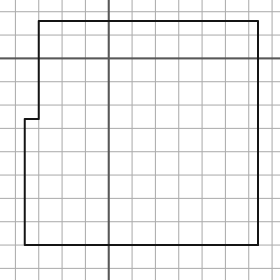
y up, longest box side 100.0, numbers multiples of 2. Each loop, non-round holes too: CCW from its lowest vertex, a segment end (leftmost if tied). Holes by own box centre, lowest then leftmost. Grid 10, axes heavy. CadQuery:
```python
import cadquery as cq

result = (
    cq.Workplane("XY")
    .moveTo(-36.0, -80.0)
    .lineTo(64.0, -80.0)
    .lineTo(64.0, 16.0)
    .lineTo(-30.0, 16.0)
    .lineTo(-30.0, -26.0)
    .lineTo(-36.0, -26.0)
    .close()
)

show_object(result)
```